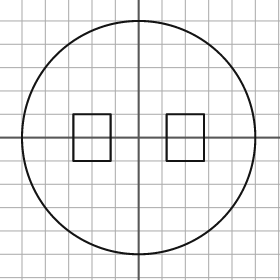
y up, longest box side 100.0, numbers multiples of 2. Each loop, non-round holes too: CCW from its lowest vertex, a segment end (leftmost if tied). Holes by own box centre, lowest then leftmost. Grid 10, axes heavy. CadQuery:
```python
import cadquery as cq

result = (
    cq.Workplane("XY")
    .moveTo(0.0, 0.0)
    .circle(50.0)
    .moveTo(-28.0, -10.0)
    .lineTo(-12.0, -10.0)
    .lineTo(-12.0, 10.0)
    .lineTo(-28.0, 10.0)
    .close()
    .moveTo(12.0, -10.0)
    .lineTo(28.0, -10.0)
    .lineTo(28.0, 10.0)
    .lineTo(12.0, 10.0)
    .close()
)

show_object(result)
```